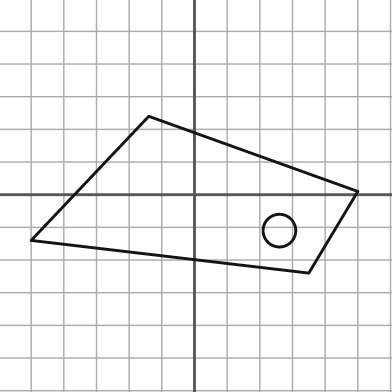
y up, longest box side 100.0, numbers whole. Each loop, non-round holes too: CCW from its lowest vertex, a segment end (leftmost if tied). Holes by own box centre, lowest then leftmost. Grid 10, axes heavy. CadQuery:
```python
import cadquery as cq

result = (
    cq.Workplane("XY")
    .moveTo(35.0, -24.0)
    .lineTo(50.0, 1.0)
    .lineTo(-14.0, 24.0)
    .lineTo(-50.0, -14.0)
    .close()
    .moveTo(26.0, -11.0)
    .circle(5.0)
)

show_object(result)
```